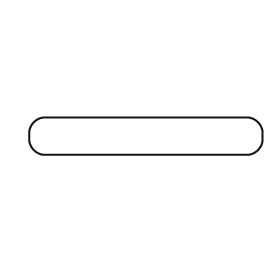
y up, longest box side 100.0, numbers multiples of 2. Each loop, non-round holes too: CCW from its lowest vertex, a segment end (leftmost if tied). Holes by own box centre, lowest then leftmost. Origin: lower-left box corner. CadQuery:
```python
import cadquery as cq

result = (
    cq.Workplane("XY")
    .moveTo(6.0, 0.0)
    .lineTo(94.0, 0.0)
    .threePointArc((98.0, 2.0), (100.0, 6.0))
    .lineTo(100.0, 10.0)
    .threePointArc((98.0, 14.0), (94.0, 16.0))
    .lineTo(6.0, 16.0)
    .threePointArc((2.0, 14.0), (0.0, 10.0))
    .lineTo(0.0, 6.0)
    .threePointArc((2.0, 2.0), (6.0, 0.0))
    .close()
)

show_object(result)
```